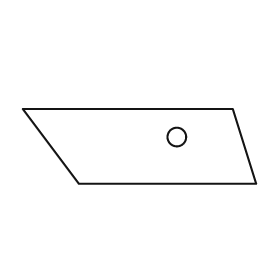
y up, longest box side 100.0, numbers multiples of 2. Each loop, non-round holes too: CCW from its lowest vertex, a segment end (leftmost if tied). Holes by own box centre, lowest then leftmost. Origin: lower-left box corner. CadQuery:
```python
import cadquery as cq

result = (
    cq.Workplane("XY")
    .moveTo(24.0, 0.0)
    .lineTo(100.0, 0.0)
    .lineTo(90.0, 32.0)
    .lineTo(0.0, 32.0)
    .close()
    .moveTo(66.0, 20.0)
    .circle(4.0)
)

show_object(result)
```